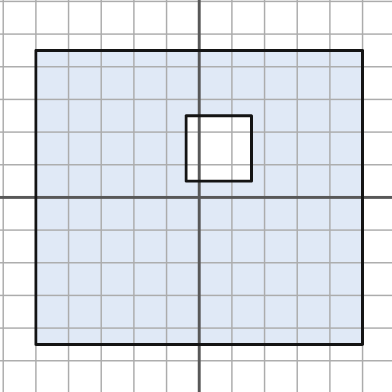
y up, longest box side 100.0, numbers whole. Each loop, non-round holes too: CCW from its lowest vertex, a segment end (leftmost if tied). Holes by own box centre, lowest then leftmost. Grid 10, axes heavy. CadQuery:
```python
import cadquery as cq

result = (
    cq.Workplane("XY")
    .moveTo(-50.0, -45.0)
    .lineTo(50.0, -45.0)
    .lineTo(50.0, 45.0)
    .lineTo(-50.0, 45.0)
    .close()
    .moveTo(-4.0, 5.0)
    .lineTo(16.0, 5.0)
    .lineTo(16.0, 25.0)
    .lineTo(-4.0, 25.0)
    .close()
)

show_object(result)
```